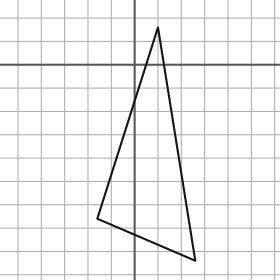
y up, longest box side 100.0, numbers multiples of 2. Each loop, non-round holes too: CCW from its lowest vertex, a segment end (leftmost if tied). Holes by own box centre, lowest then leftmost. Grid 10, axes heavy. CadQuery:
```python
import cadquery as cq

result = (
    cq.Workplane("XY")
    .moveTo(26.0, -84.0)
    .lineTo(10.0, 16.0)
    .lineTo(-16.0, -66.0)
    .close()
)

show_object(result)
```